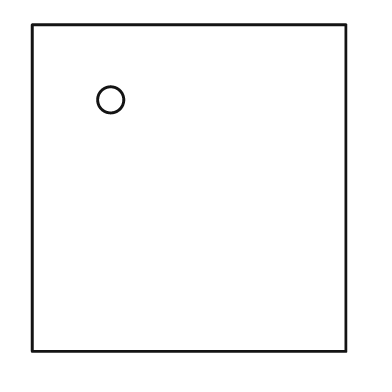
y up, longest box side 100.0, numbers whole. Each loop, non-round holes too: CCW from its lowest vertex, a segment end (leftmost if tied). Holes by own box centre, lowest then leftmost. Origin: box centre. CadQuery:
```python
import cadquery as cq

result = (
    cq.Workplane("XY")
    .moveTo(-48.0, -50.0)
    .lineTo(48.0, -50.0)
    .lineTo(48.0, 50.0)
    .lineTo(-48.0, 50.0)
    .close()
    .moveTo(-24.0, 27.0)
    .circle(4.0)
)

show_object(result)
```